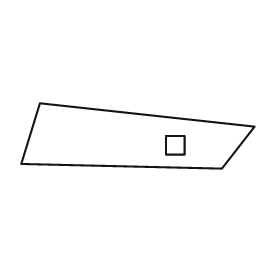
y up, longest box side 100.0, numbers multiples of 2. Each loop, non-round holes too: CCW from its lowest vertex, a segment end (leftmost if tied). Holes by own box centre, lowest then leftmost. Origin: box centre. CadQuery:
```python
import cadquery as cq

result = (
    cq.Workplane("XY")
    .moveTo(36.0, -14.0)
    .lineTo(50.0, 4.0)
    .lineTo(-42.0, 14.0)
    .lineTo(-50.0, -12.0)
    .close()
    .moveTo(12.0, -8.0)
    .lineTo(20.0, -8.0)
    .lineTo(20.0, 0.0)
    .lineTo(12.0, 0.0)
    .close()
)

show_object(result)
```